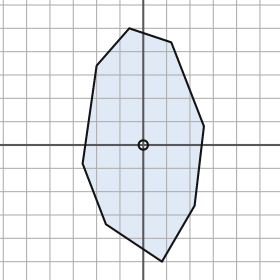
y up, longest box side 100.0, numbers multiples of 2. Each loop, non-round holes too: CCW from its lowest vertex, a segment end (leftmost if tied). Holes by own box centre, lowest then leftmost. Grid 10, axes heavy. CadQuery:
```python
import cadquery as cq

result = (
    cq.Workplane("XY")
    .moveTo(8.0, -50.0)
    .lineTo(22.0, -26.0)
    .lineTo(26.0, 8.0)
    .lineTo(12.0, 44.0)
    .lineTo(-6.0, 50.0)
    .lineTo(-20.0, 34.0)
    .lineTo(-26.0, -8.0)
    .lineTo(-16.0, -34.0)
    .close()
    .moveTo(0.0, 0.0)
    .circle(2.0)
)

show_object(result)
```